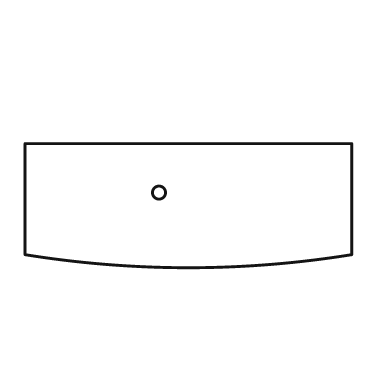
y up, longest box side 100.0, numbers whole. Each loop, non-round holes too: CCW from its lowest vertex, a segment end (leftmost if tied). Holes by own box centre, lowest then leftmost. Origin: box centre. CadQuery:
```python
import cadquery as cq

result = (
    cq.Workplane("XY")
    .moveTo(-50.0, -15.0)
    .threePointArc((0.0, -19.0), (50.0, -15.0))
    .lineTo(50.0, 19.0)
    .lineTo(-50.0, 19.0)
    .close()
    .moveTo(-9.0, 4.0)
    .circle(2.0)
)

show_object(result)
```